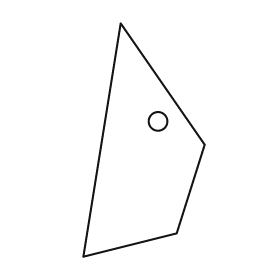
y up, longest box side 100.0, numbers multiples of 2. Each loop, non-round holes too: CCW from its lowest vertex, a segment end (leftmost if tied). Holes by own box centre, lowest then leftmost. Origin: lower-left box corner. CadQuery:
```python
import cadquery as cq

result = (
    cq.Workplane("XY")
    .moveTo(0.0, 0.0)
    .lineTo(40.0, 10.0)
    .lineTo(52.0, 48.0)
    .lineTo(16.0, 100.0)
    .close()
    .moveTo(32.0, 58.0)
    .circle(4.0)
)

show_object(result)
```